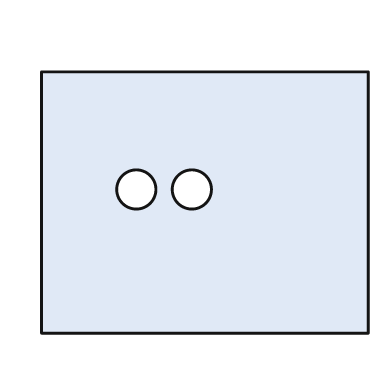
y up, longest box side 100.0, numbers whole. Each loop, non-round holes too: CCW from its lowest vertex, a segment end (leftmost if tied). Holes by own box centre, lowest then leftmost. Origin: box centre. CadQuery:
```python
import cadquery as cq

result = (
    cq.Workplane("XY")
    .moveTo(-50.0, -40.0)
    .lineTo(50.0, -40.0)
    .lineTo(50.0, 40.0)
    .lineTo(-50.0, 40.0)
    .close()
    .moveTo(-21.0, 4.0)
    .circle(6.0)
    .moveTo(-4.0, 4.0)
    .circle(6.0)
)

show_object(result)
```